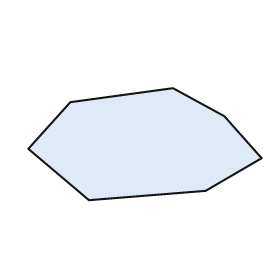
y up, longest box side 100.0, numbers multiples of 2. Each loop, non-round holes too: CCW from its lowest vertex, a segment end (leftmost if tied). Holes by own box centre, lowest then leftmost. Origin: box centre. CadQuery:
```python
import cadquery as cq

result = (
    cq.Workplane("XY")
    .moveTo(-24.0, -24.0)
    .lineTo(26.0, -20.0)
    .lineTo(50.0, -6.0)
    .lineTo(34.0, 12.0)
    .lineTo(12.0, 24.0)
    .lineTo(-32.0, 18.0)
    .lineTo(-50.0, -2.0)
    .close()
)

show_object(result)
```